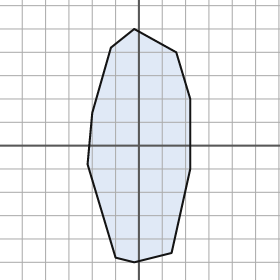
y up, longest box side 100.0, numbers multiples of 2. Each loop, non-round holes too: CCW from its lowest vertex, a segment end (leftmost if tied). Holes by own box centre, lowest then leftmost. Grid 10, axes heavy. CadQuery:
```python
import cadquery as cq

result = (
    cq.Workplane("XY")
    .moveTo(-2.0, -50.0)
    .lineTo(14.0, -46.0)
    .lineTo(22.0, -10.0)
    .lineTo(22.0, 20.0)
    .lineTo(16.0, 40.0)
    .lineTo(-2.0, 50.0)
    .lineTo(-12.0, 42.0)
    .lineTo(-20.0, 14.0)
    .lineTo(-22.0, -8.0)
    .lineTo(-10.0, -48.0)
    .close()
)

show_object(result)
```